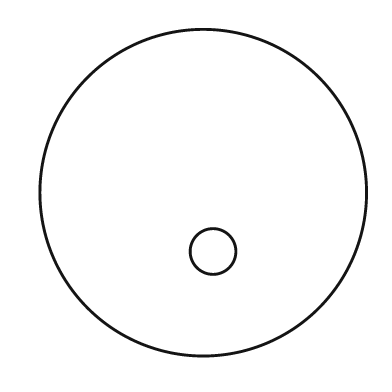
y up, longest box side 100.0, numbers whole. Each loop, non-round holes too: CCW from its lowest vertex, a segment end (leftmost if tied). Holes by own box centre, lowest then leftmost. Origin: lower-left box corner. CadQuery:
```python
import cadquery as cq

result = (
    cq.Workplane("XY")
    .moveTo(50.0, 50.0)
    .circle(50.0)
    .moveTo(53.0, 32.0)
    .circle(7.0)
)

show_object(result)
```